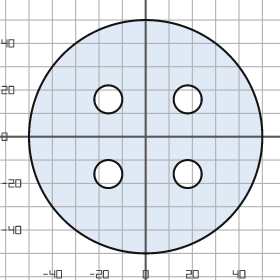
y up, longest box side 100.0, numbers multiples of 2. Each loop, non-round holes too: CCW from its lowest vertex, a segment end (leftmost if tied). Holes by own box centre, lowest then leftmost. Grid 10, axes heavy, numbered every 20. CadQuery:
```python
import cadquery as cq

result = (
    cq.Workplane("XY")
    .moveTo(0.0, 0.0)
    .circle(50.0)
    .moveTo(-16.0, -16.0)
    .circle(6.0)
    .moveTo(18.0, -16.0)
    .circle(6.0)
    .moveTo(-16.0, 16.0)
    .circle(6.0)
    .moveTo(18.0, 16.0)
    .circle(6.0)
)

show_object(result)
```